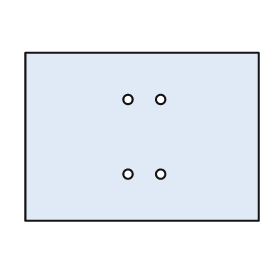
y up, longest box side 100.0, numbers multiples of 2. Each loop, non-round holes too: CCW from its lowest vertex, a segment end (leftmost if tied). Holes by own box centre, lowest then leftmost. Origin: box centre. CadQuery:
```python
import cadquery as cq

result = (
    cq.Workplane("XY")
    .moveTo(-50.0, -36.0)
    .lineTo(50.0, -36.0)
    .lineTo(50.0, 36.0)
    .lineTo(-50.0, 36.0)
    .close()
    .moveTo(-6.0, -16.0)
    .circle(2.0)
    .moveTo(8.0, -16.0)
    .circle(2.0)
    .moveTo(-6.0, 16.0)
    .circle(2.0)
    .moveTo(8.0, 16.0)
    .circle(2.0)
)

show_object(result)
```